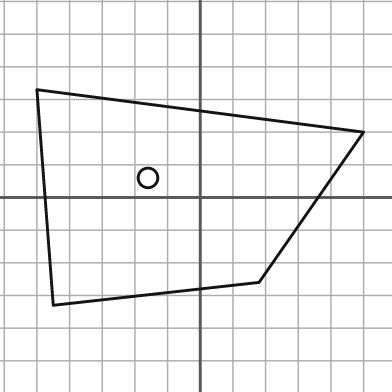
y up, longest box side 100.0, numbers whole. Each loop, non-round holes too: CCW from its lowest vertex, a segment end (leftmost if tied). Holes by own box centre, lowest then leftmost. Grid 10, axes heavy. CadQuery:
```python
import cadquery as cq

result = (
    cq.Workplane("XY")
    .moveTo(-45.0, -33.0)
    .lineTo(18.0, -26.0)
    .lineTo(50.0, 20.0)
    .lineTo(-50.0, 33.0)
    .close()
    .moveTo(-16.0, 6.0)
    .circle(3.0)
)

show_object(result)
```